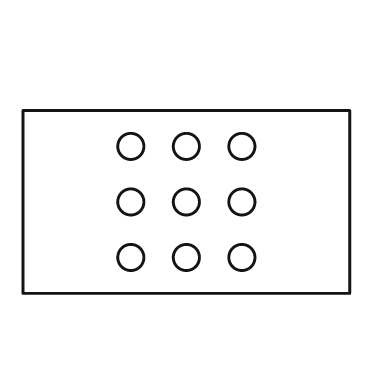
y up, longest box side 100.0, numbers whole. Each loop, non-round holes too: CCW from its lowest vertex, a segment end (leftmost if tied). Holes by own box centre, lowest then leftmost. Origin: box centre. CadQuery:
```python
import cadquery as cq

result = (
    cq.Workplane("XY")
    .moveTo(-50.0, -28.0)
    .lineTo(50.0, -28.0)
    .lineTo(50.0, 28.0)
    .lineTo(-50.0, 28.0)
    .close()
    .moveTo(-17.0, -17.0)
    .circle(4.0)
    .moveTo(0.0, -17.0)
    .circle(4.0)
    .moveTo(17.0, -17.0)
    .circle(4.0)
    .moveTo(-17.0, 0.0)
    .circle(4.0)
    .moveTo(0.0, 0.0)
    .circle(4.0)
    .moveTo(17.0, 0.0)
    .circle(4.0)
    .moveTo(-17.0, 17.0)
    .circle(4.0)
    .moveTo(0.0, 17.0)
    .circle(4.0)
    .moveTo(17.0, 17.0)
    .circle(4.0)
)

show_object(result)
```